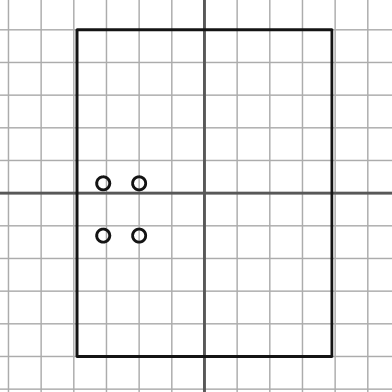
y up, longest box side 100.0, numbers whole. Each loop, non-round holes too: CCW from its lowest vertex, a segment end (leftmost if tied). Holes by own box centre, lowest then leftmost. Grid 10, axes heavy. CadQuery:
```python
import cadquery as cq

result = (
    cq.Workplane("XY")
    .moveTo(-39.0, -50.0)
    .lineTo(39.0, -50.0)
    .lineTo(39.0, 50.0)
    .lineTo(-39.0, 50.0)
    .close()
    .moveTo(-31.0, -13.0)
    .circle(2.0)
    .moveTo(-20.0, -13.0)
    .circle(2.0)
    .moveTo(-31.0, 3.0)
    .circle(2.0)
    .moveTo(-20.0, 3.0)
    .circle(2.0)
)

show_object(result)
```